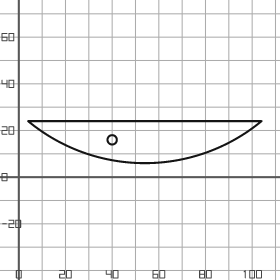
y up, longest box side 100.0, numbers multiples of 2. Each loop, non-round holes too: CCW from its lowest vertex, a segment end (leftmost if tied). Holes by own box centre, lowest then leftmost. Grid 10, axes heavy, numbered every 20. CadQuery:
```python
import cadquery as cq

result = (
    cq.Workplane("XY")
    .moveTo(4.0, 24.0)
    .threePointArc((54.0, 6.0), (104.0, 24.0))
    .close()
    .moveTo(40.0, 16.0)
    .circle(2.0)
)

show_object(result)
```